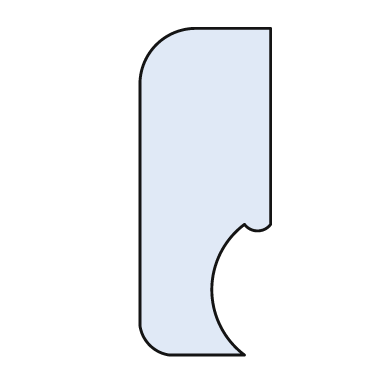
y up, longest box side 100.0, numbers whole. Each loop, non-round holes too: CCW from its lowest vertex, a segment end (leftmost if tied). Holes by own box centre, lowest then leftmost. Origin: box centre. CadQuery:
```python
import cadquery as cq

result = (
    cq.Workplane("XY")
    .moveTo(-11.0, -50.0)
    .lineTo(12.0, -50.0)
    .threePointArc((2.0, -30.0), (12.0, -10.0))
    .threePointArc((16.0, -12.0), (20.0, -10.0))
    .lineTo(20.0, 50.0)
    .lineTo(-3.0, 50.0)
    .threePointArc((-15.0, 45.0), (-20.0, 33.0))
    .lineTo(-20.0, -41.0)
    .threePointArc((-17.0, -47.0), (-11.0, -50.0))
    .close()
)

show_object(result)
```